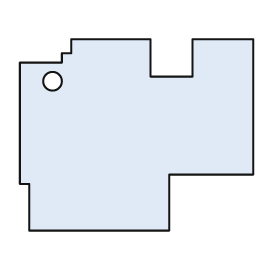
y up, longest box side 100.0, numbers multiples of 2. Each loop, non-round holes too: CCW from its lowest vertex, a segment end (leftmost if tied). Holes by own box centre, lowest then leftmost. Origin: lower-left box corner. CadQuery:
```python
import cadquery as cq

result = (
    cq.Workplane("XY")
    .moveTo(4.0, 0.0)
    .lineTo(64.0, 0.0)
    .lineTo(64.0, 24.0)
    .lineTo(100.0, 24.0)
    .lineTo(100.0, 82.0)
    .lineTo(74.0, 82.0)
    .lineTo(74.0, 66.0)
    .lineTo(56.0, 66.0)
    .lineTo(56.0, 82.0)
    .lineTo(22.0, 82.0)
    .lineTo(22.0, 76.0)
    .lineTo(18.0, 76.0)
    .lineTo(18.0, 72.0)
    .lineTo(0.0, 72.0)
    .lineTo(0.0, 20.0)
    .lineTo(4.0, 20.0)
    .close()
    .moveTo(14.0, 64.0)
    .circle(4.0)
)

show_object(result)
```